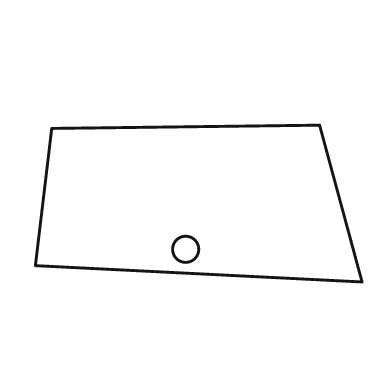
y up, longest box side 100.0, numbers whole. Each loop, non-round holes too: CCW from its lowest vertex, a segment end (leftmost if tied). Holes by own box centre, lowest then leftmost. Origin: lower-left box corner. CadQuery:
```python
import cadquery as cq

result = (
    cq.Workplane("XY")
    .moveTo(100.0, 0.0)
    .lineTo(87.0, 48.0)
    .lineTo(5.0, 47.0)
    .lineTo(0.0, 5.0)
    .close()
    .moveTo(46.0, 10.0)
    .circle(4.0)
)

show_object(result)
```